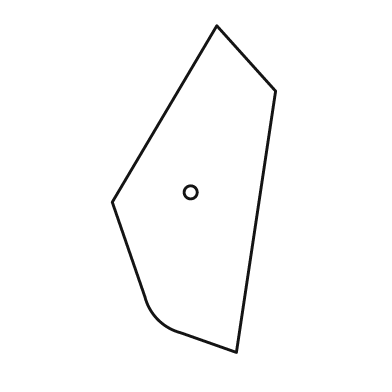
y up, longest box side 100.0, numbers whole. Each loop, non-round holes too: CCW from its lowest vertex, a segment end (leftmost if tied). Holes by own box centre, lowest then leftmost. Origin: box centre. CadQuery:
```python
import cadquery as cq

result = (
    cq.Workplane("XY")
    .moveTo(13.0, -50.0)
    .lineTo(25.0, 30.0)
    .lineTo(7.0, 50.0)
    .lineTo(-25.0, -4.0)
    .lineTo(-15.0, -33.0)
    .threePointArc((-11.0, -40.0), (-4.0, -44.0))
    .close()
    .moveTo(-1.0, -1.0)
    .circle(2.0)
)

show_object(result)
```